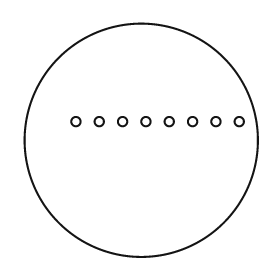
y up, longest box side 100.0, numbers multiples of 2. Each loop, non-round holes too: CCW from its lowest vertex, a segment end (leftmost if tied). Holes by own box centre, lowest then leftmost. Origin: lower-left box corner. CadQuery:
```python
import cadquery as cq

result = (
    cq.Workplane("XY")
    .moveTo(50.0, 50.0)
    .circle(50.0)
    .moveTo(22.0, 58.0)
    .circle(2.0)
    .moveTo(32.0, 58.0)
    .circle(2.0)
    .moveTo(42.0, 58.0)
    .circle(2.0)
    .moveTo(52.0, 58.0)
    .circle(2.0)
    .moveTo(62.0, 58.0)
    .circle(2.0)
    .moveTo(72.0, 58.0)
    .circle(2.0)
    .moveTo(82.0, 58.0)
    .circle(2.0)
    .moveTo(92.0, 58.0)
    .circle(2.0)
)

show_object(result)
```